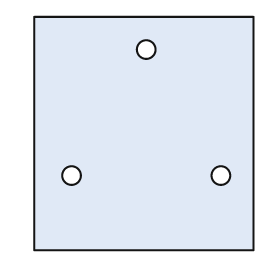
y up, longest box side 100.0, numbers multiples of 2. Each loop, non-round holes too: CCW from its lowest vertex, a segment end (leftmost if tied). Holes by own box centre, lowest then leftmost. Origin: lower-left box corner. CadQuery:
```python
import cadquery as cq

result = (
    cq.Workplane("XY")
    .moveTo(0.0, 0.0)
    .lineTo(94.0, 0.0)
    .lineTo(94.0, 100.0)
    .lineTo(0.0, 100.0)
    .close()
    .moveTo(16.0, 32.0)
    .circle(4.0)
    .moveTo(80.0, 32.0)
    .circle(4.0)
    .moveTo(48.0, 86.0)
    .circle(4.0)
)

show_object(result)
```